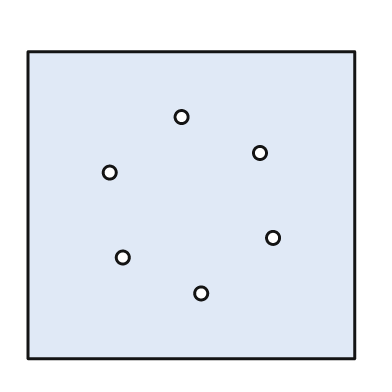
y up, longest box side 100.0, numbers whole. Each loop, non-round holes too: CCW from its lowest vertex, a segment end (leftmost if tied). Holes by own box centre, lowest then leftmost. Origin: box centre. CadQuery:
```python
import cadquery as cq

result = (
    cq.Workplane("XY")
    .moveTo(-50.0, -47.0)
    .lineTo(50.0, -47.0)
    .lineTo(50.0, 47.0)
    .lineTo(-50.0, 47.0)
    .close()
    .moveTo(3.0, -27.0)
    .circle(2.0)
    .moveTo(-21.0, -16.0)
    .circle(2.0)
    .moveTo(25.0, -10.0)
    .circle(2.0)
    .moveTo(-25.0, 10.0)
    .circle(2.0)
    .moveTo(21.0, 16.0)
    .circle(2.0)
    .moveTo(-3.0, 27.0)
    .circle(2.0)
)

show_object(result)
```